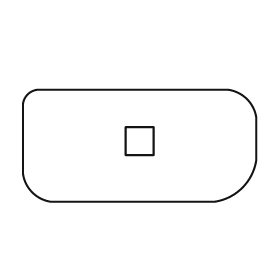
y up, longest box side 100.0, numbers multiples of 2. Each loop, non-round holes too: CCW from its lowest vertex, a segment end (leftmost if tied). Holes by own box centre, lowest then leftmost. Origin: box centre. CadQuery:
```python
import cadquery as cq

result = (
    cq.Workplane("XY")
    .moveTo(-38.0, -24.0)
    .lineTo(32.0, -24.0)
    .threePointArc((44.0, -18.0), (50.0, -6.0))
    .lineTo(50.0, 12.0)
    .threePointArc((46.0, 20.0), (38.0, 24.0))
    .lineTo(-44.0, 24.0)
    .threePointArc((-48.0, 22.0), (-50.0, 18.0))
    .lineTo(-50.0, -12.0)
    .threePointArc((-46.0, -20.0), (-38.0, -24.0))
    .close()
    .moveTo(-6.0, -4.0)
    .lineTo(6.0, -4.0)
    .lineTo(6.0, 8.0)
    .lineTo(-6.0, 8.0)
    .close()
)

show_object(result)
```